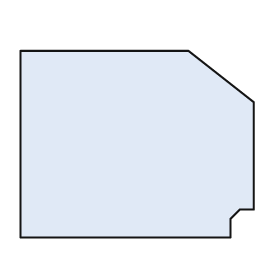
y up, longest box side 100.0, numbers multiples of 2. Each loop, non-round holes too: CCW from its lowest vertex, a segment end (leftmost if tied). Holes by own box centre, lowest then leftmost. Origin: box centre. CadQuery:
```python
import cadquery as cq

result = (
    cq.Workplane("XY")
    .moveTo(-50.0, -40.0)
    .lineTo(40.0, -40.0)
    .lineTo(40.0, -32.0)
    .lineTo(44.0, -28.0)
    .lineTo(50.0, -28.0)
    .lineTo(50.0, 18.0)
    .lineTo(22.0, 40.0)
    .lineTo(-50.0, 40.0)
    .close()
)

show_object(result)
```